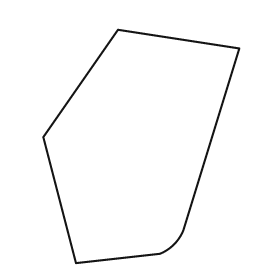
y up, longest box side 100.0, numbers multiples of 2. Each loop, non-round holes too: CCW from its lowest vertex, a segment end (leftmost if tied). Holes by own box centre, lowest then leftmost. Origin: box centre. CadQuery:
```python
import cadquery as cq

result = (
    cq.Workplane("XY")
    .moveTo(-28.0, -50.0)
    .lineTo(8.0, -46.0)
    .threePointArc((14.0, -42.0), (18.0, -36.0))
    .lineTo(42.0, 42.0)
    .lineTo(-10.0, 50.0)
    .lineTo(-42.0, 4.0)
    .close()
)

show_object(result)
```